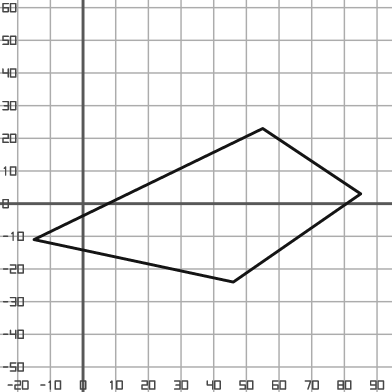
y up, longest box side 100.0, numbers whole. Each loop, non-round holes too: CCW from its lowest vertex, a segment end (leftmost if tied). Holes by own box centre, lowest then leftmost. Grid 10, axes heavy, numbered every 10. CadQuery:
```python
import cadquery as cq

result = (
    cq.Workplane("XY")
    .moveTo(46.0, -24.0)
    .lineTo(85.0, 3.0)
    .lineTo(55.0, 23.0)
    .lineTo(-15.0, -11.0)
    .close()
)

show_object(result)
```